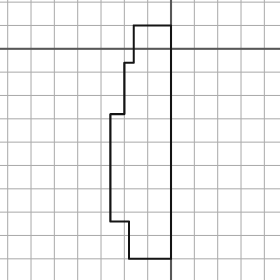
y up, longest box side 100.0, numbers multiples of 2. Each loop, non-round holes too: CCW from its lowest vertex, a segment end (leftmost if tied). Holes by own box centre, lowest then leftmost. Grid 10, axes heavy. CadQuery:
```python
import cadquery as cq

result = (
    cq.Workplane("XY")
    .moveTo(-18.0, -90.0)
    .lineTo(0.0, -90.0)
    .lineTo(0.0, 10.0)
    .lineTo(-16.0, 10.0)
    .lineTo(-16.0, -6.0)
    .lineTo(-20.0, -6.0)
    .lineTo(-20.0, -28.0)
    .lineTo(-26.0, -28.0)
    .lineTo(-26.0, -74.0)
    .lineTo(-18.0, -74.0)
    .close()
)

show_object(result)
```